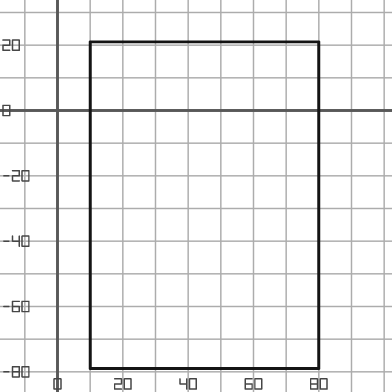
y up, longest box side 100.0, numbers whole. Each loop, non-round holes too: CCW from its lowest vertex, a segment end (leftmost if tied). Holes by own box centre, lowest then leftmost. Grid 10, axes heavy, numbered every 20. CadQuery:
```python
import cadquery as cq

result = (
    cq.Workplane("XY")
    .moveTo(10.0, -79.0)
    .lineTo(80.0, -79.0)
    .lineTo(80.0, 21.0)
    .lineTo(10.0, 21.0)
    .close()
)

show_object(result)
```